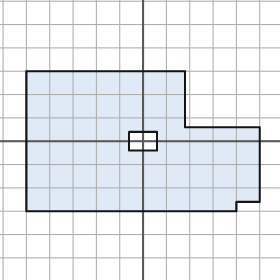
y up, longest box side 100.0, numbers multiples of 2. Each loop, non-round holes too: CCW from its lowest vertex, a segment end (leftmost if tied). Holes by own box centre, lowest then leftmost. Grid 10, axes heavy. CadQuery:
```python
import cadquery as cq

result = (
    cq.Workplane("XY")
    .moveTo(-50.0, -30.0)
    .lineTo(40.0, -30.0)
    .lineTo(40.0, -26.0)
    .lineTo(50.0, -26.0)
    .lineTo(50.0, 6.0)
    .lineTo(18.0, 6.0)
    .lineTo(18.0, 30.0)
    .lineTo(-50.0, 30.0)
    .close()
    .moveTo(-6.0, -4.0)
    .lineTo(6.0, -4.0)
    .lineTo(6.0, 4.0)
    .lineTo(-6.0, 4.0)
    .close()
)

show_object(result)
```